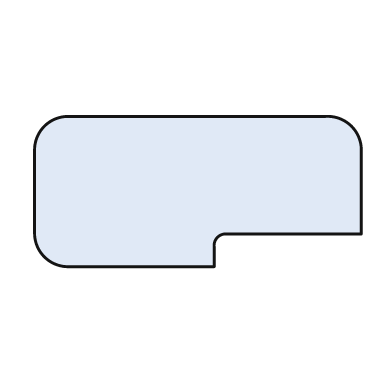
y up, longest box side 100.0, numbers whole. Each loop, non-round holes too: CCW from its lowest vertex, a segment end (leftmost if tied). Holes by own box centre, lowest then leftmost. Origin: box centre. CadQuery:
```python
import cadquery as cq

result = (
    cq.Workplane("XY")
    .moveTo(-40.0, -23.0)
    .lineTo(5.0, -23.0)
    .lineTo(5.0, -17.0)
    .threePointArc((6.0, -14.0), (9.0, -13.0))
    .lineTo(50.0, -13.0)
    .lineTo(50.0, 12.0)
    .threePointArc((47.0, 20.0), (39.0, 23.0))
    .lineTo(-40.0, 23.0)
    .threePointArc((-47.0, 20.0), (-50.0, 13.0))
    .lineTo(-50.0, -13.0)
    .threePointArc((-47.0, -20.0), (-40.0, -23.0))
    .close()
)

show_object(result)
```